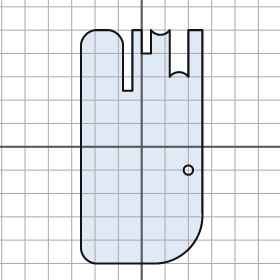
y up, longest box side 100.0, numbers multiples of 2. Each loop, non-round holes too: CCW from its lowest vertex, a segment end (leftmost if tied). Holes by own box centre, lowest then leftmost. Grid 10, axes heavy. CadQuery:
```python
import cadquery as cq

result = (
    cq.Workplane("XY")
    .moveTo(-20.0, -50.0)
    .lineTo(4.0, -50.0)
    .threePointArc((20.0, -44.0), (26.0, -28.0))
    .lineTo(26.0, 50.0)
    .lineTo(20.0, 50.0)
    .lineTo(20.0, 30.0)
    .threePointArc((16.0, 32.0), (12.0, 30.0))
    .lineTo(12.0, 50.0)
    .threePointArc((8.0, 48.0), (4.0, 50.0))
    .lineTo(4.0, 40.0)
    .lineTo(0.0, 40.0)
    .lineTo(0.0, 50.0)
    .lineTo(-4.0, 50.0)
    .lineTo(-4.0, 24.0)
    .lineTo(-8.0, 24.0)
    .lineTo(-8.0, 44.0)
    .threePointArc((-10.0, 48.0), (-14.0, 50.0))
    .lineTo(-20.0, 50.0)
    .threePointArc((-24.0, 48.0), (-26.0, 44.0))
    .lineTo(-26.0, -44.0)
    .threePointArc((-24.0, -48.0), (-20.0, -50.0))
    .close()
    .moveTo(20.0, -10.0)
    .circle(2.0)
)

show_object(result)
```